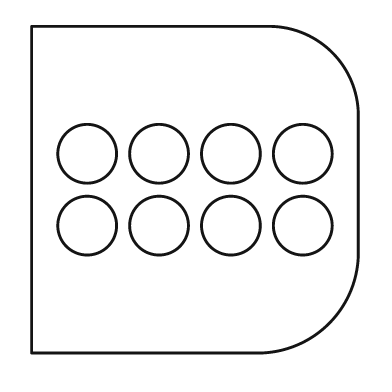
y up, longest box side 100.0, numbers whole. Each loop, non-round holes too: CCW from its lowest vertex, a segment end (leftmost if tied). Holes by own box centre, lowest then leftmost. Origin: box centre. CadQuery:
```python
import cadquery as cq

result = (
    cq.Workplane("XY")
    .moveTo(-50.0, -50.0)
    .lineTo(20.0, -50.0)
    .threePointArc((41.0, -41.0), (50.0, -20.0))
    .lineTo(50.0, 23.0)
    .threePointArc((42.0, 42.0), (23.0, 50.0))
    .lineTo(-50.0, 50.0)
    .close()
    .moveTo(-33.0, -11.0)
    .circle(9.0)
    .moveTo(-11.0, -11.0)
    .circle(9.0)
    .moveTo(11.0, -11.0)
    .circle(9.0)
    .moveTo(33.0, -11.0)
    .circle(9.0)
    .moveTo(-33.0, 11.0)
    .circle(9.0)
    .moveTo(-11.0, 11.0)
    .circle(9.0)
    .moveTo(11.0, 11.0)
    .circle(9.0)
    .moveTo(33.0, 11.0)
    .circle(9.0)
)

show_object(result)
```